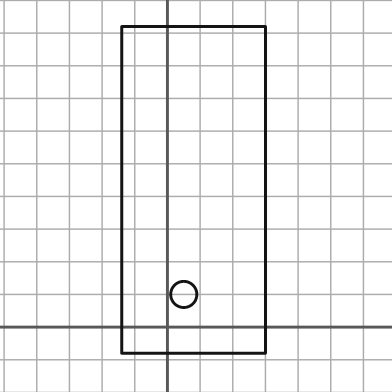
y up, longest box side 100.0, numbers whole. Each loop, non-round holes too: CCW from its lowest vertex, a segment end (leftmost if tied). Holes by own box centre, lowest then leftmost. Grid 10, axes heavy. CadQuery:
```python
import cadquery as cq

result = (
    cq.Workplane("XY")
    .moveTo(-14.0, -8.0)
    .lineTo(30.0, -8.0)
    .lineTo(30.0, 92.0)
    .lineTo(-14.0, 92.0)
    .close()
    .moveTo(5.0, 10.0)
    .circle(4.0)
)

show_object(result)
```